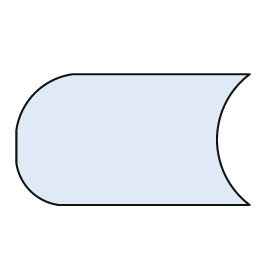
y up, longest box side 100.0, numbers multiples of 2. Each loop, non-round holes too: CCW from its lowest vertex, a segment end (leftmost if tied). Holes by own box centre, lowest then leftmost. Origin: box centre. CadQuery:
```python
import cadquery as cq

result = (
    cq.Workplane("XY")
    .moveTo(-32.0, -28.0)
    .lineTo(50.0, -28.0)
    .threePointArc((36.0, 0.0), (50.0, 28.0))
    .lineTo(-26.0, 28.0)
    .threePointArc((-42.0, 20.0), (-50.0, 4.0))
    .lineTo(-50.0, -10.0)
    .threePointArc((-44.0, -22.0), (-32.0, -28.0))
    .close()
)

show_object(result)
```